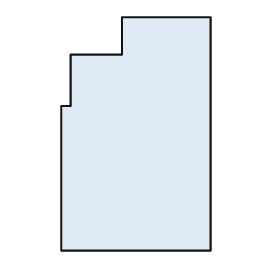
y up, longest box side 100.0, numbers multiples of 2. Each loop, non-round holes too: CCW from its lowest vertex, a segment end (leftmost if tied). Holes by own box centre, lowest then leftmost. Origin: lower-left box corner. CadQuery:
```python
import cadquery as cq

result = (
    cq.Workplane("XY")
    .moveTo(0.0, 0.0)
    .lineTo(64.0, 0.0)
    .lineTo(64.0, 100.0)
    .lineTo(26.0, 100.0)
    .lineTo(26.0, 84.0)
    .lineTo(4.0, 84.0)
    .lineTo(4.0, 62.0)
    .lineTo(0.0, 62.0)
    .close()
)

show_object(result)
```